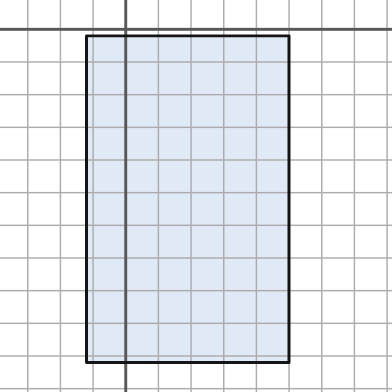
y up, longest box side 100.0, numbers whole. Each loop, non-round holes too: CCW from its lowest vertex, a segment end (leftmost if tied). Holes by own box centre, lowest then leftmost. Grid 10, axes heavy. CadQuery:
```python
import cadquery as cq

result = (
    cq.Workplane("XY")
    .moveTo(-12.0, -102.0)
    .lineTo(50.0, -102.0)
    .lineTo(50.0, -2.0)
    .lineTo(-12.0, -2.0)
    .close()
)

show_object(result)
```